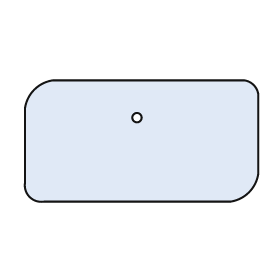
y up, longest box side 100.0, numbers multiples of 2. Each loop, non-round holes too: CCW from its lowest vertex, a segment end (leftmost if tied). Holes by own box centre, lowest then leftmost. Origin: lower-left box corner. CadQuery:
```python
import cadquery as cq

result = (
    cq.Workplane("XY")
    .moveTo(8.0, 0.0)
    .lineTo(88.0, 0.0)
    .threePointArc((96.0, 4.0), (100.0, 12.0))
    .lineTo(100.0, 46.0)
    .threePointArc((98.0, 50.0), (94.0, 52.0))
    .lineTo(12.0, 52.0)
    .threePointArc((4.0, 48.0), (0.0, 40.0))
    .lineTo(0.0, 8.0)
    .threePointArc((2.0, 2.0), (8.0, 0.0))
    .close()
    .moveTo(48.0, 36.0)
    .circle(2.0)
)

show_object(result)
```